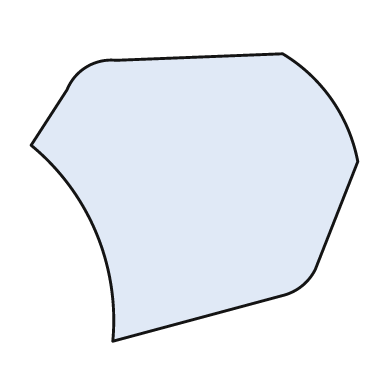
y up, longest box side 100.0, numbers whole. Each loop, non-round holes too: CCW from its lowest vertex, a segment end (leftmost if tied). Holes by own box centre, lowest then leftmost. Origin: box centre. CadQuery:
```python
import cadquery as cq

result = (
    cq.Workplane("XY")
    .moveTo(-25.0, -44.0)
    .lineTo(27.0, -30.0)
    .threePointArc((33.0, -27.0), (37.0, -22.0))
    .lineTo(50.0, 11.0)
    .threePointArc((42.0, 30.0), (27.0, 44.0))
    .lineTo(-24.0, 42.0)
    .threePointArc((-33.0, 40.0), (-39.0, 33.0))
    .lineTo(-50.0, 16.0)
    .threePointArc((-30.0, -11.0), (-25.0, -44.0))
    .close()
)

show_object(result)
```